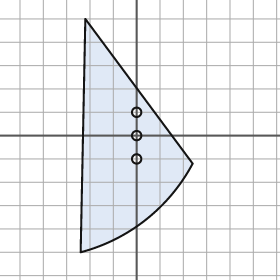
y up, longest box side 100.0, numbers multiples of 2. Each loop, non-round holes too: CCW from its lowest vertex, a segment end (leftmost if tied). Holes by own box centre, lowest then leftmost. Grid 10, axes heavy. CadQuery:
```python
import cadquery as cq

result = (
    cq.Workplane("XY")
    .moveTo(-24.0, -50.0)
    .threePointArc((4.0, -36.0), (24.0, -12.0))
    .lineTo(-22.0, 50.0)
    .close()
    .moveTo(0.0, -10.0)
    .circle(2.0)
    .moveTo(0.0, 0.0)
    .circle(2.0)
    .moveTo(0.0, 10.0)
    .circle(2.0)
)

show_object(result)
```